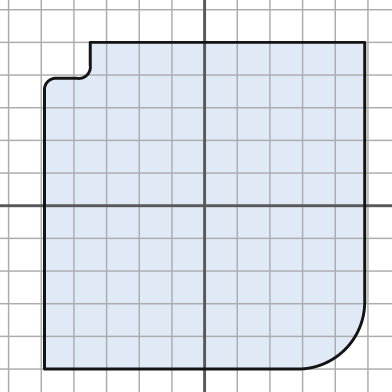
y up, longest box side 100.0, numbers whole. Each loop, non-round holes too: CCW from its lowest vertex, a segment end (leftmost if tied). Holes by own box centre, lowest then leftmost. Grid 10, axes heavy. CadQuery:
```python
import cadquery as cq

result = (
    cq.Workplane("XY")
    .moveTo(-49.0, -50.0)
    .lineTo(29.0, -50.0)
    .threePointArc((43.0, -44.0), (49.0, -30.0))
    .lineTo(49.0, 50.0)
    .lineTo(-35.0, 50.0)
    .lineTo(-35.0, 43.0)
    .threePointArc((-36.0, 40.0), (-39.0, 39.0))
    .lineTo(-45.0, 39.0)
    .threePointArc((-48.0, 38.0), (-49.0, 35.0))
    .close()
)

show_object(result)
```